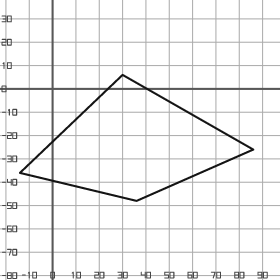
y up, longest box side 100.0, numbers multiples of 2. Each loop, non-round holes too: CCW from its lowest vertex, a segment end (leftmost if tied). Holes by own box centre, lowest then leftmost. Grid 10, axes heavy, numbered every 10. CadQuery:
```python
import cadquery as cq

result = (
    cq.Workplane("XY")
    .moveTo(36.0, -48.0)
    .lineTo(86.0, -26.0)
    .lineTo(30.0, 6.0)
    .lineTo(-14.0, -36.0)
    .close()
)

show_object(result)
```